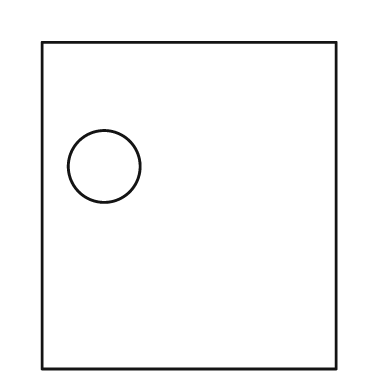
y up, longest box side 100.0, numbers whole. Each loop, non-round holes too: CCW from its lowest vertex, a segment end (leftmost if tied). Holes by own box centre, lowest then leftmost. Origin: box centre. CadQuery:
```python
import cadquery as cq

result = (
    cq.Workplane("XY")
    .moveTo(-45.0, -50.0)
    .lineTo(45.0, -50.0)
    .lineTo(45.0, 50.0)
    .lineTo(-45.0, 50.0)
    .close()
    .moveTo(-26.0, 12.0)
    .circle(11.0)
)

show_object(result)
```